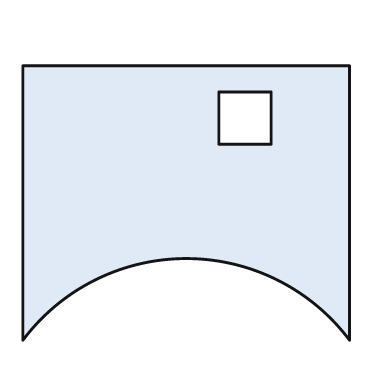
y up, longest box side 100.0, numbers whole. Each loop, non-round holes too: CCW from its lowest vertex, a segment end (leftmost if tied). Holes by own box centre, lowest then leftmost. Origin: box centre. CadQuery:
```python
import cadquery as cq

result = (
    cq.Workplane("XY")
    .moveTo(-50.0, -42.0)
    .threePointArc((0.0, -17.0), (50.0, -42.0))
    .lineTo(50.0, 42.0)
    .lineTo(-50.0, 42.0)
    .close()
    .moveTo(10.0, 18.0)
    .lineTo(26.0, 18.0)
    .lineTo(26.0, 34.0)
    .lineTo(10.0, 34.0)
    .close()
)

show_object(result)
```